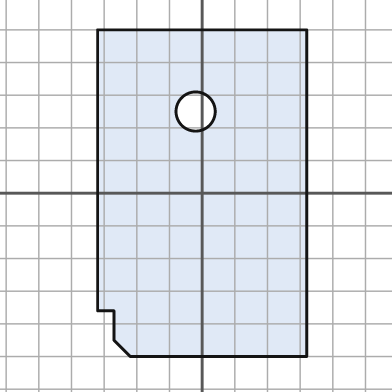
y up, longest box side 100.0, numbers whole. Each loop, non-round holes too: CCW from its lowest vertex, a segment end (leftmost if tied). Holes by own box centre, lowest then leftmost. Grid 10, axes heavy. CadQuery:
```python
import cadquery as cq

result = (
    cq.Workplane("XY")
    .moveTo(-22.0, -50.0)
    .lineTo(32.0, -50.0)
    .lineTo(32.0, 50.0)
    .lineTo(-32.0, 50.0)
    .lineTo(-32.0, -36.0)
    .lineTo(-27.0, -36.0)
    .lineTo(-27.0, -45.0)
    .close()
    .moveTo(-2.0, 25.0)
    .circle(6.0)
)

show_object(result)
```